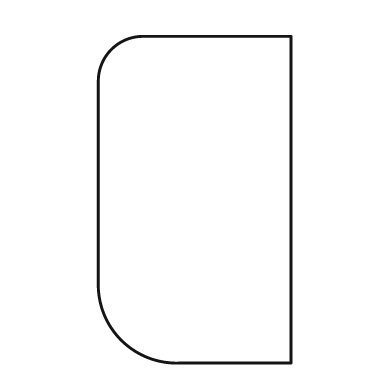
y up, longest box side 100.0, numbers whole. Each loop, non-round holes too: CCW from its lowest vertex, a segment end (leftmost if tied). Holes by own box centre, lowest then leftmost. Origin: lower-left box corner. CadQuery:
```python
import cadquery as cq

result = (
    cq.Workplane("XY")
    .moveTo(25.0, 0.0)
    .lineTo(59.0, 0.0)
    .lineTo(59.0, 100.0)
    .lineTo(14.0, 100.0)
    .threePointArc((4.0, 96.0), (0.0, 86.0))
    .lineTo(0.0, 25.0)
    .threePointArc((7.0, 7.0), (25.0, 0.0))
    .close()
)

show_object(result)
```